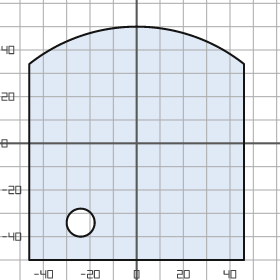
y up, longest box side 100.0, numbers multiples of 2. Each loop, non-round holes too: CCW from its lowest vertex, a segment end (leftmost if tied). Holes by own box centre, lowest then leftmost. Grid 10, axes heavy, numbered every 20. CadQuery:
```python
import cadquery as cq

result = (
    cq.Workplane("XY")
    .moveTo(-46.0, -50.0)
    .lineTo(46.0, -50.0)
    .lineTo(46.0, 34.0)
    .threePointArc((0.0, 50.0), (-46.0, 34.0))
    .close()
    .moveTo(-24.0, -34.0)
    .circle(6.0)
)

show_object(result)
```